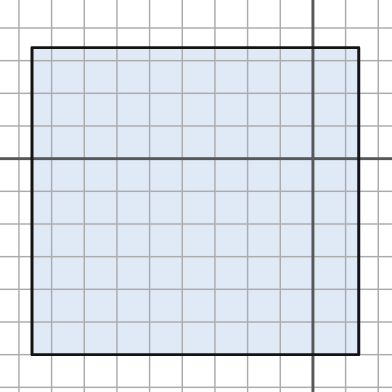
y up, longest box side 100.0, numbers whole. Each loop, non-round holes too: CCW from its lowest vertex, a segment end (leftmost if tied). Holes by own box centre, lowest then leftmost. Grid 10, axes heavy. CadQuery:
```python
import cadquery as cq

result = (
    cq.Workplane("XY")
    .moveTo(-86.0, -60.0)
    .lineTo(14.0, -60.0)
    .lineTo(14.0, 34.0)
    .lineTo(-86.0, 34.0)
    .close()
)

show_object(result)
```